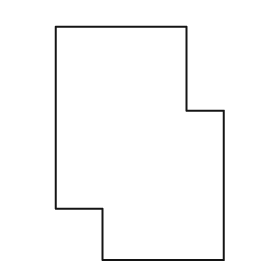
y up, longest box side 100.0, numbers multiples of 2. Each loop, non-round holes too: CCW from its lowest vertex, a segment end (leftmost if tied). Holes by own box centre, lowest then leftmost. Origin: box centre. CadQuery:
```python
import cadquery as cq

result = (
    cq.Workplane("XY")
    .moveTo(-16.0, -50.0)
    .lineTo(36.0, -50.0)
    .lineTo(36.0, 14.0)
    .lineTo(20.0, 14.0)
    .lineTo(20.0, 50.0)
    .lineTo(-36.0, 50.0)
    .lineTo(-36.0, -28.0)
    .lineTo(-16.0, -28.0)
    .close()
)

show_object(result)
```